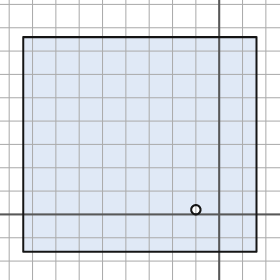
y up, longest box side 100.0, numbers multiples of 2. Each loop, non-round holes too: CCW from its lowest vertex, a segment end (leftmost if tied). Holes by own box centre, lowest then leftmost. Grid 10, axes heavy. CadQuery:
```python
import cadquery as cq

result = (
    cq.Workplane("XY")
    .moveTo(-84.0, -16.0)
    .lineTo(16.0, -16.0)
    .lineTo(16.0, 76.0)
    .lineTo(-84.0, 76.0)
    .close()
    .moveTo(-10.0, 2.0)
    .circle(2.0)
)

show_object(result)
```